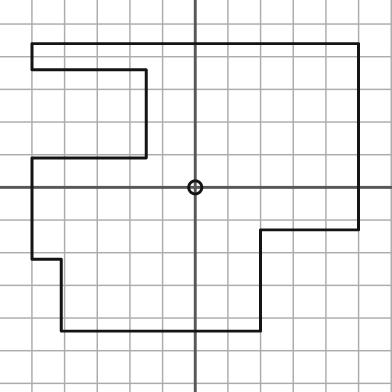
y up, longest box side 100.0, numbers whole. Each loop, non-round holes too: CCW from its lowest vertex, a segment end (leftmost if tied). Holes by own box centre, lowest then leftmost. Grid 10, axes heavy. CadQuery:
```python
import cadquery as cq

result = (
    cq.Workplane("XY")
    .moveTo(-41.0, -44.0)
    .lineTo(20.0, -44.0)
    .lineTo(20.0, -13.0)
    .lineTo(50.0, -13.0)
    .lineTo(50.0, 44.0)
    .lineTo(-50.0, 44.0)
    .lineTo(-50.0, 36.0)
    .lineTo(-15.0, 36.0)
    .lineTo(-15.0, 9.0)
    .lineTo(-50.0, 9.0)
    .lineTo(-50.0, -22.0)
    .lineTo(-41.0, -22.0)
    .close()
    .moveTo(0.0, 0.0)
    .circle(2.0)
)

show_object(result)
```